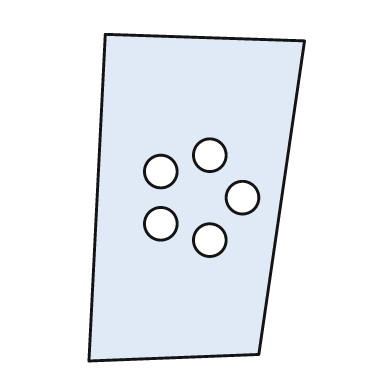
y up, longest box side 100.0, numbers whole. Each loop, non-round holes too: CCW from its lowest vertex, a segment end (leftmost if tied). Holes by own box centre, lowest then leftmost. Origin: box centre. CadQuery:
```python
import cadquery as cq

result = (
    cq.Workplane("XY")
    .moveTo(-33.0, -50.0)
    .lineTo(19.0, -48.0)
    .lineTo(33.0, 48.0)
    .lineTo(-28.0, 50.0)
    .close()
    .moveTo(4.0, -13.0)
    .circle(5.0)
    .moveTo(-11.0, -8.0)
    .circle(5.0)
    .moveTo(14.0, 0.0)
    .circle(5.0)
    .moveTo(-11.0, 8.0)
    .circle(5.0)
    .moveTo(4.0, 13.0)
    .circle(5.0)
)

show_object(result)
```